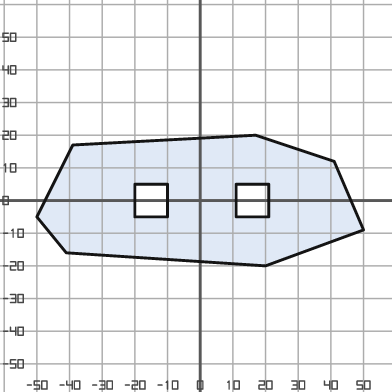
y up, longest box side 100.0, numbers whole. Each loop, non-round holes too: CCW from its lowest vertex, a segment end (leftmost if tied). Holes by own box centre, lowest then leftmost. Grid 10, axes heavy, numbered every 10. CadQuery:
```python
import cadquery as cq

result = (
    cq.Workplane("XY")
    .moveTo(20.0, -20.0)
    .lineTo(50.0, -9.0)
    .lineTo(41.0, 12.0)
    .lineTo(17.0, 20.0)
    .lineTo(-39.0, 17.0)
    .lineTo(-50.0, -5.0)
    .lineTo(-41.0, -16.0)
    .close()
    .moveTo(-20.0, -5.0)
    .lineTo(-10.0, -5.0)
    .lineTo(-10.0, 5.0)
    .lineTo(-20.0, 5.0)
    .close()
    .moveTo(11.0, -5.0)
    .lineTo(21.0, -5.0)
    .lineTo(21.0, 5.0)
    .lineTo(11.0, 5.0)
    .close()
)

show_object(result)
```